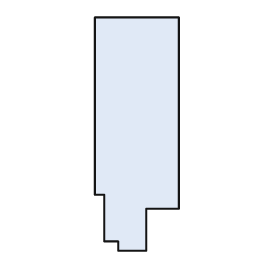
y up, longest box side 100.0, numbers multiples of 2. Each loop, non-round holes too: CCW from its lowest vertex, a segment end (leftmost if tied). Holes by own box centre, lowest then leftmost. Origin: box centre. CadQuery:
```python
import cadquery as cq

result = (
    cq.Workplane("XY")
    .moveTo(-8.0, -50.0)
    .lineTo(4.0, -50.0)
    .lineTo(4.0, -32.0)
    .lineTo(18.0, -32.0)
    .lineTo(18.0, 50.0)
    .lineTo(-18.0, 50.0)
    .lineTo(-18.0, -26.0)
    .lineTo(-14.0, -26.0)
    .lineTo(-14.0, -46.0)
    .lineTo(-8.0, -46.0)
    .close()
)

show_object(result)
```